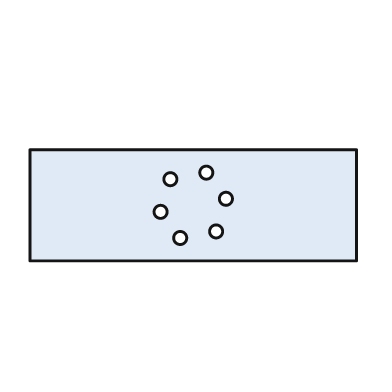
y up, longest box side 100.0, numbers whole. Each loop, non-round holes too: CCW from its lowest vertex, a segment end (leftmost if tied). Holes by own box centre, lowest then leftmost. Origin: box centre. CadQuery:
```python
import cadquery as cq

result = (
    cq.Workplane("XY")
    .moveTo(-50.0, -17.0)
    .lineTo(50.0, -17.0)
    .lineTo(50.0, 17.0)
    .lineTo(-50.0, 17.0)
    .close()
    .moveTo(-4.0, -10.0)
    .circle(2.0)
    .moveTo(7.0, -8.0)
    .circle(2.0)
    .moveTo(-10.0, -2.0)
    .circle(2.0)
    .moveTo(10.0, 2.0)
    .circle(2.0)
    .moveTo(-7.0, 8.0)
    .circle(2.0)
    .moveTo(4.0, 10.0)
    .circle(2.0)
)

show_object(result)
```